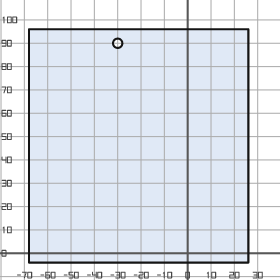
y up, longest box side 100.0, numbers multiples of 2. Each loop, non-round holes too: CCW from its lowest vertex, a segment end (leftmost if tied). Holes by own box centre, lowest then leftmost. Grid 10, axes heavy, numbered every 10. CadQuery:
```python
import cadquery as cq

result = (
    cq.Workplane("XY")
    .moveTo(-68.0, -4.0)
    .lineTo(26.0, -4.0)
    .lineTo(26.0, 96.0)
    .lineTo(-68.0, 96.0)
    .close()
    .moveTo(-30.0, 90.0)
    .circle(2.0)
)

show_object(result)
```